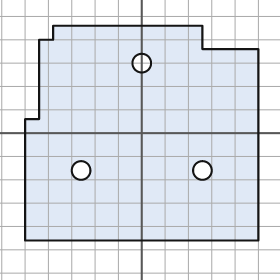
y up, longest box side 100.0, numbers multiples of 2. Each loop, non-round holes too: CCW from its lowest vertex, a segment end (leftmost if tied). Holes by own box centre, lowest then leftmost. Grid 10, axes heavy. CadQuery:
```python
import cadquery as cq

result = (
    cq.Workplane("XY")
    .moveTo(-50.0, -46.0)
    .lineTo(50.0, -46.0)
    .lineTo(50.0, 36.0)
    .lineTo(26.0, 36.0)
    .lineTo(26.0, 46.0)
    .lineTo(-38.0, 46.0)
    .lineTo(-38.0, 40.0)
    .lineTo(-44.0, 40.0)
    .lineTo(-44.0, 6.0)
    .lineTo(-50.0, 6.0)
    .close()
    .moveTo(-26.0, -16.0)
    .circle(4.0)
    .moveTo(26.0, -16.0)
    .circle(4.0)
    .moveTo(0.0, 30.0)
    .circle(4.0)
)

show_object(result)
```